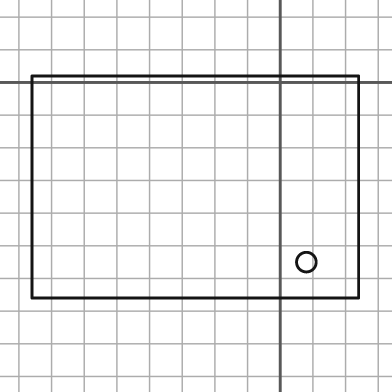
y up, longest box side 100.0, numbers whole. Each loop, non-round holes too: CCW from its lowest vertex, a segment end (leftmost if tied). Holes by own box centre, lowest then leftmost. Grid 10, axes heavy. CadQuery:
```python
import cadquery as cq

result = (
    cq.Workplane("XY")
    .moveTo(-76.0, -66.0)
    .lineTo(24.0, -66.0)
    .lineTo(24.0, 2.0)
    .lineTo(-76.0, 2.0)
    .close()
    .moveTo(8.0, -55.0)
    .circle(3.0)
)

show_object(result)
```